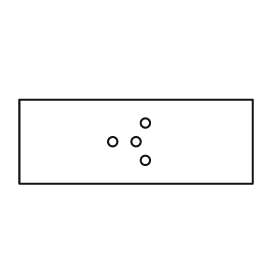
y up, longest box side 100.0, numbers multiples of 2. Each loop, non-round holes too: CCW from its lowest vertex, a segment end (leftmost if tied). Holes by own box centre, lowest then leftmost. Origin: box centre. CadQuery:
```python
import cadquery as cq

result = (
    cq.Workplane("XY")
    .moveTo(-50.0, -18.0)
    .lineTo(50.0, -18.0)
    .lineTo(50.0, 18.0)
    .lineTo(-50.0, 18.0)
    .close()
    .moveTo(4.0, -8.0)
    .circle(2.0)
    .moveTo(-10.0, 0.0)
    .circle(2.0)
    .moveTo(0.0, 0.0)
    .circle(2.0)
    .moveTo(4.0, 8.0)
    .circle(2.0)
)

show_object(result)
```